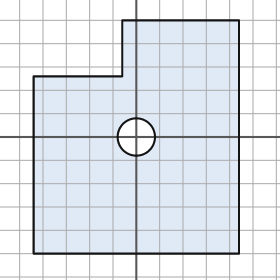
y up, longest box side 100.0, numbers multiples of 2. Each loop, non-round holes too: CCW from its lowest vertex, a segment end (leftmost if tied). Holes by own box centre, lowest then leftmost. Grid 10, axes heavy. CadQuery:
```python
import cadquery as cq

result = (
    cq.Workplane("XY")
    .moveTo(-44.0, -50.0)
    .lineTo(44.0, -50.0)
    .lineTo(44.0, 50.0)
    .lineTo(-6.0, 50.0)
    .lineTo(-6.0, 26.0)
    .lineTo(-44.0, 26.0)
    .close()
    .moveTo(0.0, 0.0)
    .circle(8.0)
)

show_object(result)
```